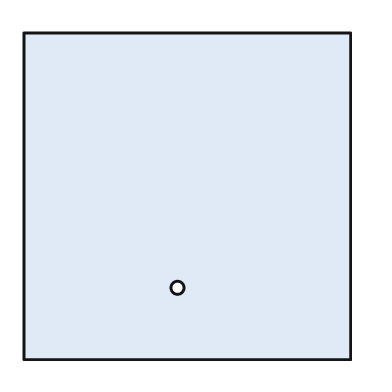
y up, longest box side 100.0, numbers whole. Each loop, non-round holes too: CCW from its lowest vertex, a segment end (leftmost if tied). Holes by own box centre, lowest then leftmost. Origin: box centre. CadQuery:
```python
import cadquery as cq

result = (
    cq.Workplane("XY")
    .moveTo(-50.0, -50.0)
    .lineTo(50.0, -50.0)
    .lineTo(50.0, 50.0)
    .lineTo(-50.0, 50.0)
    .close()
    .moveTo(-3.0, -28.0)
    .circle(2.0)
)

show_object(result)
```